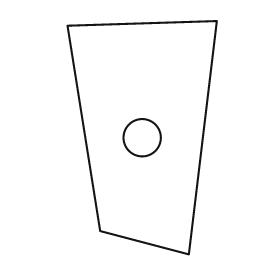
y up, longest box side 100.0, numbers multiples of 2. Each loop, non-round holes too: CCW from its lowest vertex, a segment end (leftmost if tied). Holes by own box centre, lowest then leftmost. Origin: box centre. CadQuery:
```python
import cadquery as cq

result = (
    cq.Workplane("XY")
    .moveTo(20.0, -50.0)
    .lineTo(32.0, 50.0)
    .lineTo(-32.0, 48.0)
    .lineTo(-18.0, -40.0)
    .close()
    .moveTo(0.0, 0.0)
    .circle(8.0)
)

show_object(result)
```